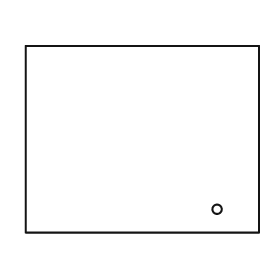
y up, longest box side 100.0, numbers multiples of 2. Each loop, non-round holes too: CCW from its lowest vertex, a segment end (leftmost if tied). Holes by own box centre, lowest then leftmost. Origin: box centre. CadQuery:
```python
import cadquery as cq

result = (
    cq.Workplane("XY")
    .moveTo(-50.0, -40.0)
    .lineTo(50.0, -40.0)
    .lineTo(50.0, 40.0)
    .lineTo(-50.0, 40.0)
    .close()
    .moveTo(32.0, -30.0)
    .circle(2.0)
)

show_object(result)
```